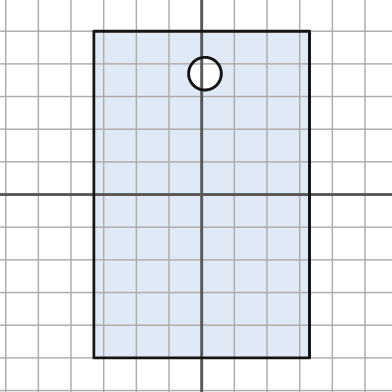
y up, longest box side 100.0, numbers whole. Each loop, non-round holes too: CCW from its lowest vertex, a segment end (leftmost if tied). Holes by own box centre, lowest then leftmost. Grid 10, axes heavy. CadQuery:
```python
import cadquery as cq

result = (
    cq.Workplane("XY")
    .moveTo(-33.0, -50.0)
    .lineTo(33.0, -50.0)
    .lineTo(33.0, 50.0)
    .lineTo(-33.0, 50.0)
    .close()
    .moveTo(1.0, 37.0)
    .circle(5.0)
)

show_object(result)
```